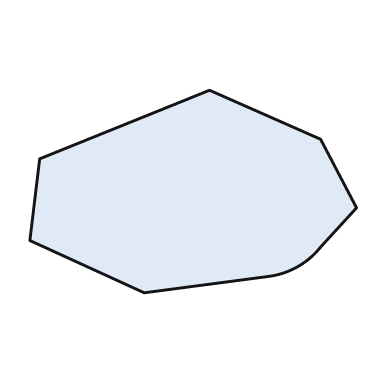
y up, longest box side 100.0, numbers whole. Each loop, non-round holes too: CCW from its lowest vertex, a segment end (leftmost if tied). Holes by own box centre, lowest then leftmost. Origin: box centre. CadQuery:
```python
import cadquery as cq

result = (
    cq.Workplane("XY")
    .moveTo(-15.0, -31.0)
    .lineTo(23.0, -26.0)
    .threePointArc((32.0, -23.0), (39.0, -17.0))
    .lineTo(50.0, -5.0)
    .lineTo(39.0, 16.0)
    .lineTo(5.0, 31.0)
    .lineTo(-47.0, 10.0)
    .lineTo(-50.0, -15.0)
    .close()
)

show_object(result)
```